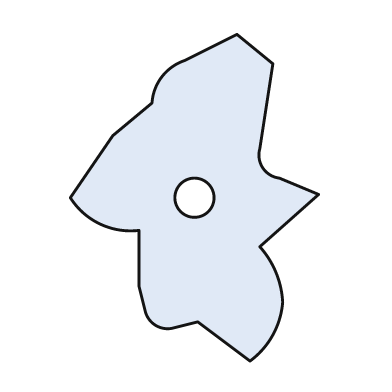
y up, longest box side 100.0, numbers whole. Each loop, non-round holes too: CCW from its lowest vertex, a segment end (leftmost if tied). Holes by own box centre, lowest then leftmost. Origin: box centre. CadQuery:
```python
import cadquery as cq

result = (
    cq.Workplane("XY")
    .moveTo(17.0, -50.0)
    .threePointArc((24.0, -42.0), (27.0, -32.0))
    .threePointArc((25.0, -23.0), (20.0, -15.0))
    .lineTo(38.0, 1.0)
    .lineTo(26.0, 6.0)
    .threePointArc((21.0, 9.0), (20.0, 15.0))
    .lineTo(24.0, 41.0)
    .lineTo(13.0, 50.0)
    .lineTo(-3.0, 42.0)
    .threePointArc((-10.0, 37.0), (-13.0, 29.0))
    .lineTo(-25.0, 19.0)
    .lineTo(-38.0, 0.0)
    .threePointArc((-29.0, -8.0), (-17.0, -10.0))
    .lineTo(-17.0, -27.0)
    .lineTo(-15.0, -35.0)
    .threePointArc((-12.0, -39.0), (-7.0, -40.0))
    .lineTo(1.0, -38.0)
    .close()
    .moveTo(0.0, 0.0)
    .circle(6.0)
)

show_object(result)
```